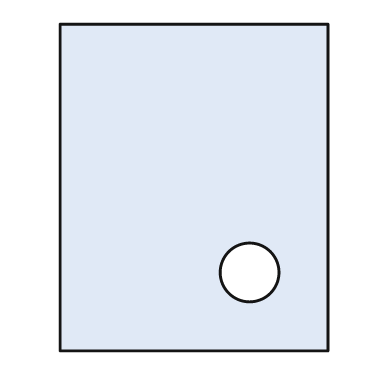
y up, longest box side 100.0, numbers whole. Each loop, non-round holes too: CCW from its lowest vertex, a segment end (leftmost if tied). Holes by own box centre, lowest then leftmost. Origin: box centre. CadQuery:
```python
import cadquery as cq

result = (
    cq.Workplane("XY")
    .moveTo(-41.0, -50.0)
    .lineTo(41.0, -50.0)
    .lineTo(41.0, 50.0)
    .lineTo(-41.0, 50.0)
    .close()
    .moveTo(17.0, -26.0)
    .circle(9.0)
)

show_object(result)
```